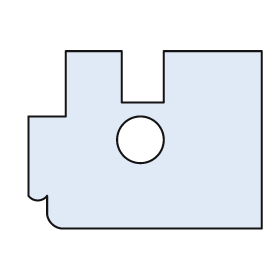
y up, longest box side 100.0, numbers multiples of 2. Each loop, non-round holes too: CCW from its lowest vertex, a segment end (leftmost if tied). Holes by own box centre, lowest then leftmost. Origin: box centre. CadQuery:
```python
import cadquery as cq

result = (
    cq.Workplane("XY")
    .moveTo(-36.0, -38.0)
    .lineTo(50.0, -38.0)
    .lineTo(50.0, 38.0)
    .lineTo(8.0, 38.0)
    .lineTo(8.0, 16.0)
    .lineTo(-10.0, 16.0)
    .lineTo(-10.0, 38.0)
    .lineTo(-34.0, 38.0)
    .lineTo(-34.0, 10.0)
    .lineTo(-50.0, 10.0)
    .lineTo(-50.0, -24.0)
    .threePointArc((-46.0, -26.0), (-42.0, -24.0))
    .lineTo(-42.0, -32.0)
    .threePointArc((-40.0, -36.0), (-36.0, -38.0))
    .close()
    .moveTo(-2.0, 0.0)
    .circle(10.0)
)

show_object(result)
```